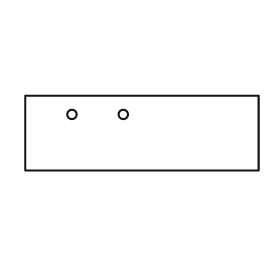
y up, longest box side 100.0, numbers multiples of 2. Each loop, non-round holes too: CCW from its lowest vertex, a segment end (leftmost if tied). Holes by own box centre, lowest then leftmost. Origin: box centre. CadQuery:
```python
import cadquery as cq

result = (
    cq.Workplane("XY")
    .moveTo(-50.0, -16.0)
    .lineTo(50.0, -16.0)
    .lineTo(50.0, 16.0)
    .lineTo(-50.0, 16.0)
    .close()
    .moveTo(-30.0, 8.0)
    .circle(2.0)
    .moveTo(-8.0, 8.0)
    .circle(2.0)
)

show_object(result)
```